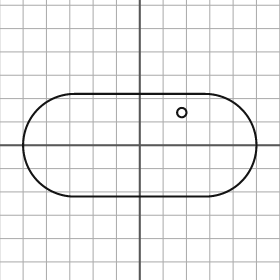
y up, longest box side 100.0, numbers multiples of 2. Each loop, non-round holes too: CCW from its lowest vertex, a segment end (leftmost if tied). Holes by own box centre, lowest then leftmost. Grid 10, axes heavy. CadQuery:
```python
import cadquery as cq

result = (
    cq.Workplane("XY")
    .moveTo(-28.0, -22.0)
    .lineTo(28.0, -22.0)
    .threePointArc((50.0, 0.0), (28.0, 22.0))
    .lineTo(-28.0, 22.0)
    .threePointArc((-50.0, 0.0), (-28.0, -22.0))
    .close()
    .moveTo(18.0, 14.0)
    .circle(2.0)
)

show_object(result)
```